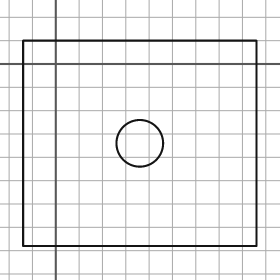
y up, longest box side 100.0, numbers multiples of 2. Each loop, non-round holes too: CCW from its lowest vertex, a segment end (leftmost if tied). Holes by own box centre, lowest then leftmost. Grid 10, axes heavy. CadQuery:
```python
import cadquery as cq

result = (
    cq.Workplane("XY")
    .moveTo(-14.0, -78.0)
    .lineTo(86.0, -78.0)
    .lineTo(86.0, 10.0)
    .lineTo(-14.0, 10.0)
    .close()
    .moveTo(36.0, -34.0)
    .circle(10.0)
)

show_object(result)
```